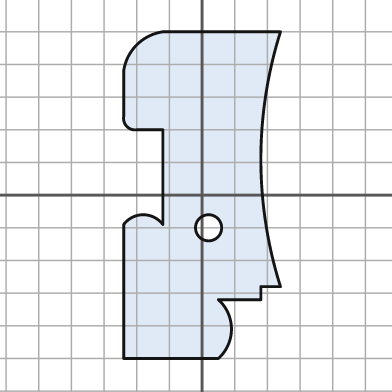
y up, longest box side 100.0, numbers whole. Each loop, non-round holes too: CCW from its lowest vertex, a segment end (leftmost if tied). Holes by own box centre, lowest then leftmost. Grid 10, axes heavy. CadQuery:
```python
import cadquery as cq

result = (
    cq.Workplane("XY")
    .moveTo(-24.0, -50.0)
    .lineTo(5.0, -50.0)
    .threePointArc((9.0, -41.0), (5.0, -32.0))
    .lineTo(18.0, -32.0)
    .lineTo(18.0, -28.0)
    .lineTo(24.0, -28.0)
    .threePointArc((18.0, 11.0), (24.0, 50.0))
    .lineTo(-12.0, 50.0)
    .threePointArc((-20.0, 46.0), (-24.0, 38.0))
    .lineTo(-24.0, 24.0)
    .threePointArc((-23.0, 21.0), (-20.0, 20.0))
    .lineTo(-12.0, 20.0)
    .lineTo(-12.0, -9.0)
    .threePointArc((-18.0, -6.0), (-24.0, -9.0))
    .close()
    .moveTo(2.0, -10.0)
    .circle(4.0)
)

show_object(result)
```